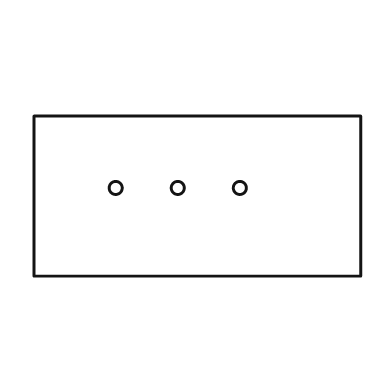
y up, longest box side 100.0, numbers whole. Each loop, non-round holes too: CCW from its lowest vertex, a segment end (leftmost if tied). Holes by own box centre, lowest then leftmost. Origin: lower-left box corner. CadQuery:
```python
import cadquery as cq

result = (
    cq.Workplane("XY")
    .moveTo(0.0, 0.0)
    .lineTo(100.0, 0.0)
    .lineTo(100.0, 49.0)
    .lineTo(0.0, 49.0)
    .close()
    .moveTo(25.0, 27.0)
    .circle(2.0)
    .moveTo(44.0, 27.0)
    .circle(2.0)
    .moveTo(63.0, 27.0)
    .circle(2.0)
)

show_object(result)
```